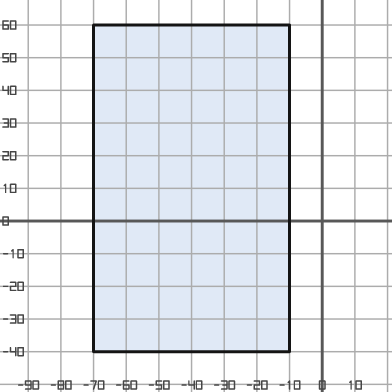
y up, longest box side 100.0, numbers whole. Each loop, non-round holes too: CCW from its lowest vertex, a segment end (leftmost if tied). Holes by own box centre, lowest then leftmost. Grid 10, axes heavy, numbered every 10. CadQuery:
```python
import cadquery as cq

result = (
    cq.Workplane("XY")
    .moveTo(-70.0, -40.0)
    .lineTo(-10.0, -40.0)
    .lineTo(-10.0, 60.0)
    .lineTo(-70.0, 60.0)
    .close()
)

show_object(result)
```